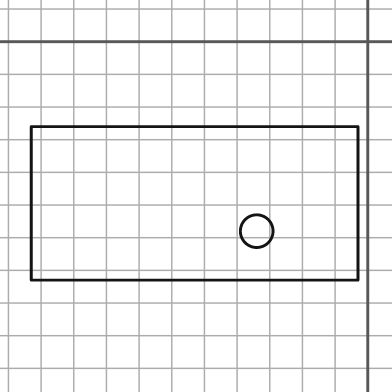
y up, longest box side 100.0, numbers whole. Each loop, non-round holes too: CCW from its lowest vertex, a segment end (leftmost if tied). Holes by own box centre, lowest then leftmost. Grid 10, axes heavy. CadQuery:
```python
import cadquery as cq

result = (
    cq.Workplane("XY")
    .moveTo(-103.0, -73.0)
    .lineTo(-3.0, -73.0)
    .lineTo(-3.0, -26.0)
    .lineTo(-103.0, -26.0)
    .close()
    .moveTo(-34.0, -58.0)
    .circle(5.0)
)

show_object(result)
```